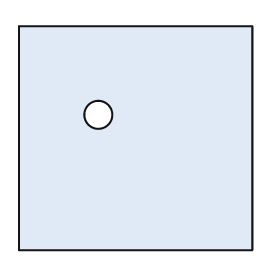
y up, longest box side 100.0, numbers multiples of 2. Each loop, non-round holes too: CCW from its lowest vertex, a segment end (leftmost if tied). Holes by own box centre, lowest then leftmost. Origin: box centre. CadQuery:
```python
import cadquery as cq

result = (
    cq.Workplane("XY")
    .moveTo(-50.0, -48.0)
    .lineTo(50.0, -48.0)
    .lineTo(50.0, 48.0)
    .lineTo(-50.0, 48.0)
    .close()
    .moveTo(-16.0, 10.0)
    .circle(6.0)
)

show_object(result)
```